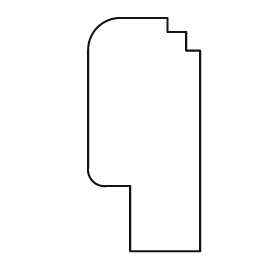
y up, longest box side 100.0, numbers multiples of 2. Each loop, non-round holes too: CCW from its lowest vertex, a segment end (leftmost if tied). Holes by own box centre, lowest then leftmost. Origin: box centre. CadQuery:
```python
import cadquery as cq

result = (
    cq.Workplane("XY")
    .moveTo(-6.0, -50.0)
    .lineTo(24.0, -50.0)
    .lineTo(24.0, 36.0)
    .lineTo(18.0, 36.0)
    .lineTo(18.0, 44.0)
    .lineTo(10.0, 44.0)
    .lineTo(10.0, 50.0)
    .lineTo(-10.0, 50.0)
    .threePointArc((-20.0, 46.0), (-24.0, 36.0))
    .lineTo(-24.0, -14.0)
    .threePointArc((-22.0, -20.0), (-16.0, -22.0))
    .lineTo(-6.0, -22.0)
    .close()
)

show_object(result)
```